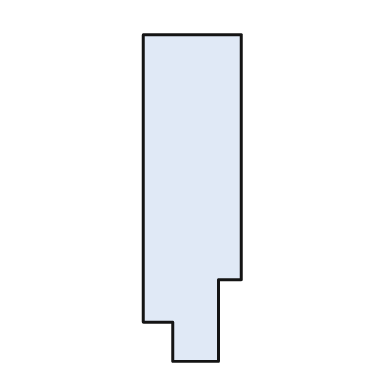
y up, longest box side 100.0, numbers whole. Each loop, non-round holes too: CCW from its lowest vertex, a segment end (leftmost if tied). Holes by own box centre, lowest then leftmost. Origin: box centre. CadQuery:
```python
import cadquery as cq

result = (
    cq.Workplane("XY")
    .moveTo(-6.0, -50.0)
    .lineTo(8.0, -50.0)
    .lineTo(8.0, -25.0)
    .lineTo(15.0, -25.0)
    .lineTo(15.0, 50.0)
    .lineTo(-15.0, 50.0)
    .lineTo(-15.0, -38.0)
    .lineTo(-6.0, -38.0)
    .close()
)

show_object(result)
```